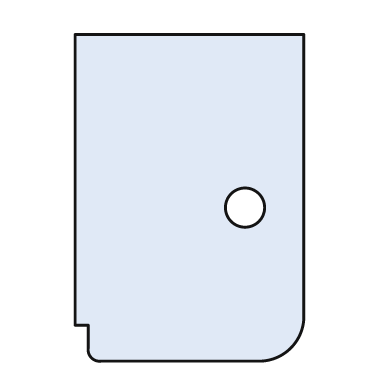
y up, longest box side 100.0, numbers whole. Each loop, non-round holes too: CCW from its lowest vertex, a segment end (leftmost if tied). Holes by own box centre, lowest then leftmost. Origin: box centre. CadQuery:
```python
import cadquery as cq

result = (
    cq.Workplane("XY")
    .moveTo(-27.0, -50.0)
    .lineTo(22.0, -50.0)
    .threePointArc((31.0, -46.0), (35.0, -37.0))
    .lineTo(35.0, 50.0)
    .lineTo(-35.0, 50.0)
    .lineTo(-35.0, -39.0)
    .lineTo(-31.0, -39.0)
    .lineTo(-31.0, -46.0)
    .threePointArc((-30.0, -49.0), (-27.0, -50.0))
    .close()
    .moveTo(17.0, -3.0)
    .circle(6.0)
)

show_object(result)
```